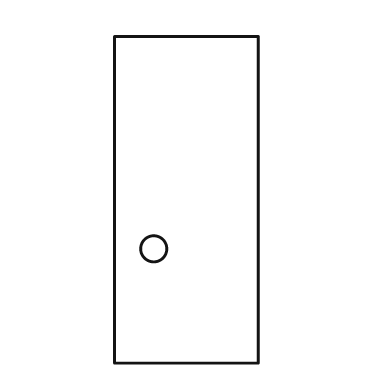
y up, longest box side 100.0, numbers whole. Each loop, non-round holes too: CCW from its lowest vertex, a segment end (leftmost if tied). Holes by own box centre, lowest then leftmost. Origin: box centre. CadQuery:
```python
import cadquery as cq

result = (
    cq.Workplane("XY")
    .moveTo(-22.0, -50.0)
    .lineTo(22.0, -50.0)
    .lineTo(22.0, 50.0)
    .lineTo(-22.0, 50.0)
    .close()
    .moveTo(-10.0, -15.0)
    .circle(4.0)
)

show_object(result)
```